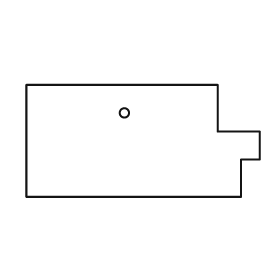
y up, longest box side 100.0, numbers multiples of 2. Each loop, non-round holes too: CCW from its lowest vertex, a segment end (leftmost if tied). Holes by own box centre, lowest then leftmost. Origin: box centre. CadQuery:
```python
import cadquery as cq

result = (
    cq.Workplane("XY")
    .moveTo(-50.0, -24.0)
    .lineTo(42.0, -24.0)
    .lineTo(42.0, -8.0)
    .lineTo(50.0, -8.0)
    .lineTo(50.0, 4.0)
    .lineTo(32.0, 4.0)
    .lineTo(32.0, 24.0)
    .lineTo(-50.0, 24.0)
    .close()
    .moveTo(-8.0, 12.0)
    .circle(2.0)
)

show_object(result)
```